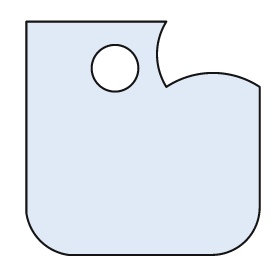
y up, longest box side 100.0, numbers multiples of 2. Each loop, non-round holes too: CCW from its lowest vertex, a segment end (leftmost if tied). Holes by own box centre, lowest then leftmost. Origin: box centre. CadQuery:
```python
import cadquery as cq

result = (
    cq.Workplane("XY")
    .moveTo(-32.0, -50.0)
    .lineTo(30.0, -50.0)
    .threePointArc((44.0, -44.0), (50.0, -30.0))
    .lineTo(50.0, 22.0)
    .threePointArc((30.0, 28.0), (10.0, 22.0))
    .threePointArc((6.0, 36.0), (10.0, 50.0))
    .lineTo(-50.0, 50.0)
    .lineTo(-50.0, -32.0)
    .threePointArc((-44.0, -44.0), (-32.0, -50.0))
    .close()
    .moveTo(-12.0, 30.0)
    .circle(10.0)
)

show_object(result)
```